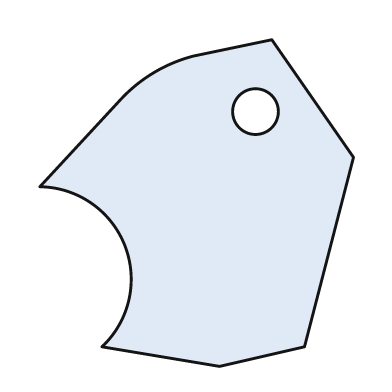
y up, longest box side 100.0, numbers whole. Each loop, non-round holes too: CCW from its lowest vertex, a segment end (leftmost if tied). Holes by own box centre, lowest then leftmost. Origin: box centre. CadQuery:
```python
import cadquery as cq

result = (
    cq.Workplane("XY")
    .moveTo(7.0, -50.0)
    .lineTo(33.0, -44.0)
    .lineTo(48.0, 14.0)
    .lineTo(23.0, 50.0)
    .lineTo(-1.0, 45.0)
    .threePointArc((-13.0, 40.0), (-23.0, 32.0))
    .lineTo(-48.0, 5.0)
    .threePointArc((-22.0, -13.0), (-29.0, -44.0))
    .close()
    .moveTo(18.0, 28.0)
    .circle(7.0)
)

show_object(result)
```